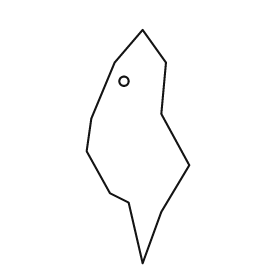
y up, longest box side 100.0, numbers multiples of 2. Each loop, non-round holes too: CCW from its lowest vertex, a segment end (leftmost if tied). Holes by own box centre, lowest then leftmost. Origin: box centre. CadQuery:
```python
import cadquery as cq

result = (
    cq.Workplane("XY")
    .moveTo(2.0, -50.0)
    .lineTo(10.0, -28.0)
    .lineTo(22.0, -8.0)
    .lineTo(10.0, 14.0)
    .lineTo(12.0, 36.0)
    .lineTo(2.0, 50.0)
    .lineTo(-10.0, 36.0)
    .lineTo(-20.0, 12.0)
    .lineTo(-22.0, -2.0)
    .lineTo(-12.0, -20.0)
    .lineTo(-4.0, -24.0)
    .close()
    .moveTo(-6.0, 28.0)
    .circle(2.0)
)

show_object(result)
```